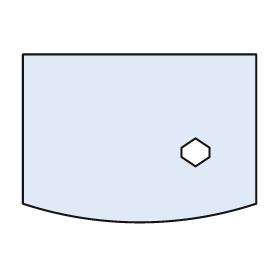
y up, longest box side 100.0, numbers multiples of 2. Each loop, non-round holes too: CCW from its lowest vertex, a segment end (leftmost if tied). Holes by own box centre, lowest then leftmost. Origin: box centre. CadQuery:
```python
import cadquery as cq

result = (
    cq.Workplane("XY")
    .moveTo(-50.0, -28.0)
    .threePointArc((0.0, -36.0), (50.0, -28.0))
    .lineTo(50.0, 36.0)
    .lineTo(-50.0, 36.0)
    .close()
    .moveTo(24.0, -12.0)
    .lineTo(30.0, -8.0)
    .lineTo(30.0, -4.0)
    .lineTo(24.0, 0.0)
    .lineTo(18.0, -4.0)
    .lineTo(18.0, -8.0)
    .close()
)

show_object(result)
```